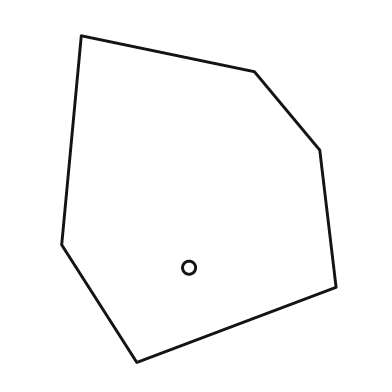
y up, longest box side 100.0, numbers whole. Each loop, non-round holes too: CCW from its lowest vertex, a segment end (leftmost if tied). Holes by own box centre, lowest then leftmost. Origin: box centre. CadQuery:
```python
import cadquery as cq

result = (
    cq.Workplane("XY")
    .moveTo(-19.0, -50.0)
    .lineTo(42.0, -27.0)
    .lineTo(37.0, 15.0)
    .lineTo(17.0, 39.0)
    .lineTo(-36.0, 50.0)
    .lineTo(-42.0, -14.0)
    .close()
    .moveTo(-3.0, -21.0)
    .circle(2.0)
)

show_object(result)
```